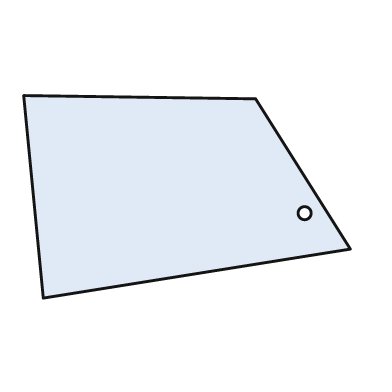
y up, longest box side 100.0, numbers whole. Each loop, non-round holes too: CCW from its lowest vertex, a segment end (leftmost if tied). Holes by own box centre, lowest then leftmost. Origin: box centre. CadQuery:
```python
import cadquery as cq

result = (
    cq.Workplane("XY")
    .moveTo(-44.0, -31.0)
    .lineTo(50.0, -16.0)
    .lineTo(21.0, 30.0)
    .lineTo(-50.0, 31.0)
    .close()
    .moveTo(36.0, -5.0)
    .circle(2.0)
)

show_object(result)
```